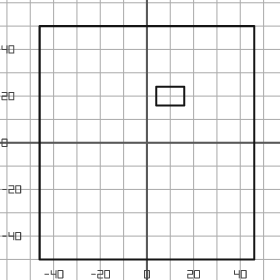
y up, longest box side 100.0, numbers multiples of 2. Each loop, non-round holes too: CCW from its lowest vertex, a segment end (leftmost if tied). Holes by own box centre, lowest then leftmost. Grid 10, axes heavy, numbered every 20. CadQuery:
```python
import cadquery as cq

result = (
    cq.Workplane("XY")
    .moveTo(-46.0, -50.0)
    .lineTo(46.0, -50.0)
    .lineTo(46.0, 50.0)
    .lineTo(-46.0, 50.0)
    .close()
    .moveTo(4.0, 16.0)
    .lineTo(16.0, 16.0)
    .lineTo(16.0, 24.0)
    .lineTo(4.0, 24.0)
    .close()
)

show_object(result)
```